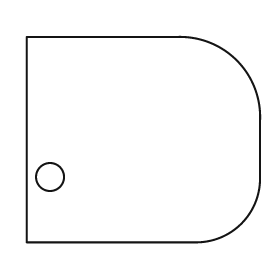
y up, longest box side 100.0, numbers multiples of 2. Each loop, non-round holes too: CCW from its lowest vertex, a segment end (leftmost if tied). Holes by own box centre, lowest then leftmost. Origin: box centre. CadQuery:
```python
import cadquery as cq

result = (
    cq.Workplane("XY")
    .moveTo(-50.0, -44.0)
    .lineTo(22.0, -44.0)
    .threePointArc((42.0, -36.0), (50.0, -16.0))
    .lineTo(50.0, 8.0)
    .threePointArc((40.0, 34.0), (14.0, 44.0))
    .lineTo(-50.0, 44.0)
    .close()
    .moveTo(-40.0, -16.0)
    .circle(6.0)
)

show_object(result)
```